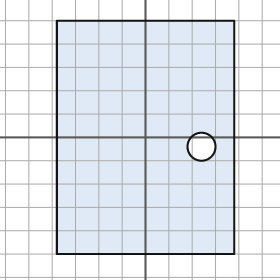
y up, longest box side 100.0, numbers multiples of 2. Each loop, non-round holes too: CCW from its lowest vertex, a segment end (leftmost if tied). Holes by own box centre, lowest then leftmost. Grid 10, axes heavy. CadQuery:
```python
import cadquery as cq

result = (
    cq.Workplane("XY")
    .moveTo(-38.0, -50.0)
    .lineTo(38.0, -50.0)
    .lineTo(38.0, 50.0)
    .lineTo(-38.0, 50.0)
    .close()
    .moveTo(24.0, -4.0)
    .circle(6.0)
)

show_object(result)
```